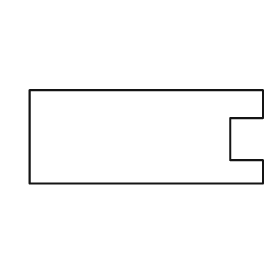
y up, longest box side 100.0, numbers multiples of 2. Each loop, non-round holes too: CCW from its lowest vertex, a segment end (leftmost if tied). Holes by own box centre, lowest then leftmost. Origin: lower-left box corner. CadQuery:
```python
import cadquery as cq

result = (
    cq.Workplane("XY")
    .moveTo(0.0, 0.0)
    .lineTo(100.0, 0.0)
    .lineTo(100.0, 10.0)
    .lineTo(86.0, 10.0)
    .lineTo(86.0, 28.0)
    .lineTo(100.0, 28.0)
    .lineTo(100.0, 40.0)
    .lineTo(0.0, 40.0)
    .close()
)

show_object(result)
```